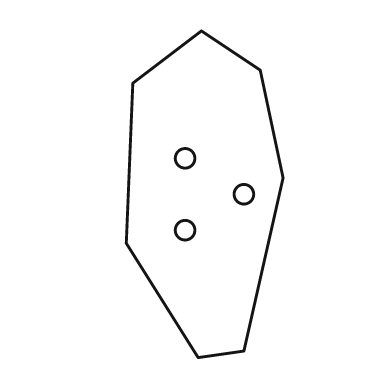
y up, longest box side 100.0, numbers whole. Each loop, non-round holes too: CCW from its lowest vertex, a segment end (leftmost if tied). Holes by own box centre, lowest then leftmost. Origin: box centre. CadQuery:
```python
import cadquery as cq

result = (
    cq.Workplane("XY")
    .moveTo(-2.0, -50.0)
    .lineTo(12.0, -48.0)
    .lineTo(24.0, 5.0)
    .lineTo(17.0, 38.0)
    .lineTo(-1.0, 50.0)
    .lineTo(-22.0, 34.0)
    .lineTo(-24.0, -15.0)
    .close()
    .moveTo(-6.0, -11.0)
    .circle(3.0)
    .moveTo(12.0, 0.0)
    .circle(3.0)
    .moveTo(-6.0, 11.0)
    .circle(3.0)
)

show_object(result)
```